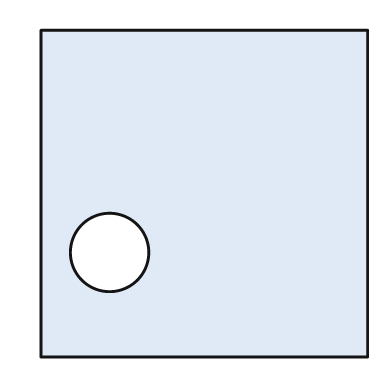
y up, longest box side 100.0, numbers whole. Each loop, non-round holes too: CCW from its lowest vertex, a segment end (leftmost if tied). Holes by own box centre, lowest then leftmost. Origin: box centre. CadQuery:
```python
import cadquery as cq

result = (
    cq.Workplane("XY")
    .moveTo(-50.0, -50.0)
    .lineTo(50.0, -50.0)
    .lineTo(50.0, 50.0)
    .lineTo(-50.0, 50.0)
    .close()
    .moveTo(-29.0, -18.0)
    .circle(12.0)
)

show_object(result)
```